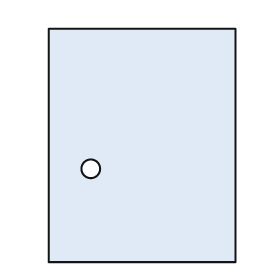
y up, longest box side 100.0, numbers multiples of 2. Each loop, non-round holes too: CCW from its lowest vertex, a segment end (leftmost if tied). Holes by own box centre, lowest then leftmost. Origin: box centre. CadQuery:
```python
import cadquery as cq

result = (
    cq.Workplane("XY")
    .moveTo(-40.0, -50.0)
    .lineTo(40.0, -50.0)
    .lineTo(40.0, 50.0)
    .lineTo(-40.0, 50.0)
    .close()
    .moveTo(-22.0, -10.0)
    .circle(4.0)
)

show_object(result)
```